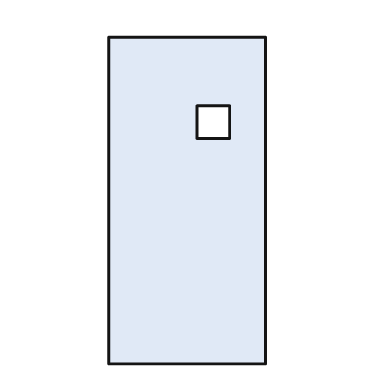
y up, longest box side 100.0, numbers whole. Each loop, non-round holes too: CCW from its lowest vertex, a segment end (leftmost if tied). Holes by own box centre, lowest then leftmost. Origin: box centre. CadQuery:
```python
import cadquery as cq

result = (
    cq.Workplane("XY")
    .moveTo(-24.0, -50.0)
    .lineTo(24.0, -50.0)
    .lineTo(24.0, 50.0)
    .lineTo(-24.0, 50.0)
    .close()
    .moveTo(3.0, 19.0)
    .lineTo(13.0, 19.0)
    .lineTo(13.0, 29.0)
    .lineTo(3.0, 29.0)
    .close()
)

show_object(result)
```